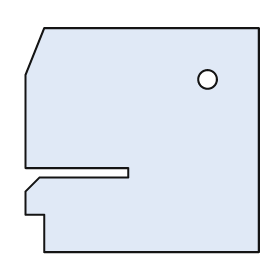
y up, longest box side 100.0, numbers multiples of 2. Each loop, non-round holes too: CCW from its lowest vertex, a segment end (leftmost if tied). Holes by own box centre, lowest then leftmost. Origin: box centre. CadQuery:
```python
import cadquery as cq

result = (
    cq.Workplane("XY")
    .moveTo(-42.0, -48.0)
    .lineTo(50.0, -48.0)
    .lineTo(50.0, 48.0)
    .lineTo(-42.0, 48.0)
    .lineTo(-50.0, 28.0)
    .lineTo(-50.0, -12.0)
    .lineTo(-6.0, -12.0)
    .lineTo(-6.0, -16.0)
    .lineTo(-44.0, -16.0)
    .lineTo(-50.0, -22.0)
    .lineTo(-50.0, -32.0)
    .lineTo(-42.0, -32.0)
    .close()
    .moveTo(28.0, 26.0)
    .circle(4.0)
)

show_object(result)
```